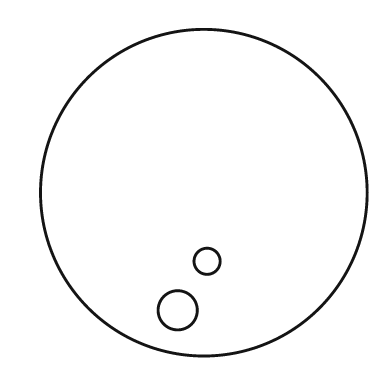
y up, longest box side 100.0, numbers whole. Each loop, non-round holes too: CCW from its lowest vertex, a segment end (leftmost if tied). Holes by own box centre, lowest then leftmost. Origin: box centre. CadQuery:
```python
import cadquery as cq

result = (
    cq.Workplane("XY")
    .moveTo(0.0, 0.0)
    .circle(50.0)
    .moveTo(-8.0, -36.0)
    .circle(6.0)
    .moveTo(1.0, -21.0)
    .circle(4.0)
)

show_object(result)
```